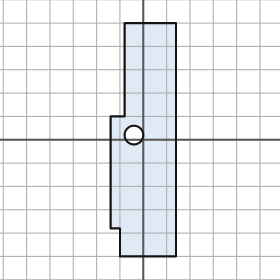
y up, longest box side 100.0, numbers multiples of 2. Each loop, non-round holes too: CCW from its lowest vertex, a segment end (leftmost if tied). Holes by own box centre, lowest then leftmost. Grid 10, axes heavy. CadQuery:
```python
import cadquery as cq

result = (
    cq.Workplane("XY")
    .moveTo(-10.0, -50.0)
    .lineTo(14.0, -50.0)
    .lineTo(14.0, 50.0)
    .lineTo(-8.0, 50.0)
    .lineTo(-8.0, 10.0)
    .lineTo(-14.0, 10.0)
    .lineTo(-14.0, -38.0)
    .lineTo(-10.0, -38.0)
    .close()
    .moveTo(-4.0, 2.0)
    .circle(4.0)
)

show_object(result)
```